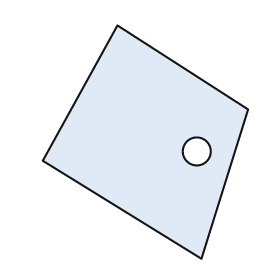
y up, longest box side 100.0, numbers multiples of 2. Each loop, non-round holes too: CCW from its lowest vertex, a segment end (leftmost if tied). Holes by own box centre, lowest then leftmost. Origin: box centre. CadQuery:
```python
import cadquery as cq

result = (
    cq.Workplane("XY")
    .moveTo(24.0, -50.0)
    .lineTo(44.0, 14.0)
    .lineTo(-12.0, 50.0)
    .lineTo(-44.0, -8.0)
    .close()
    .moveTo(22.0, -4.0)
    .circle(6.0)
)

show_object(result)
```